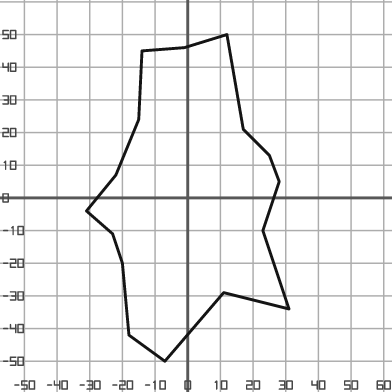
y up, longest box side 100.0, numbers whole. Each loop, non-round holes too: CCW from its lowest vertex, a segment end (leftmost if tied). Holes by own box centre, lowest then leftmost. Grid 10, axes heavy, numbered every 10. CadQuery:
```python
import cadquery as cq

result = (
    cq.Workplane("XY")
    .moveTo(-7.0, -50.0)
    .lineTo(11.0, -29.0)
    .lineTo(31.0, -34.0)
    .lineTo(23.0, -10.0)
    .lineTo(28.0, 5.0)
    .lineTo(25.0, 13.0)
    .lineTo(17.0, 21.0)
    .lineTo(12.0, 50.0)
    .lineTo(-1.0, 46.0)
    .lineTo(-14.0, 45.0)
    .lineTo(-15.0, 24.0)
    .lineTo(-22.0, 7.0)
    .lineTo(-31.0, -4.0)
    .lineTo(-23.0, -11.0)
    .lineTo(-20.0, -20.0)
    .lineTo(-18.0, -42.0)
    .close()
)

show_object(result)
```